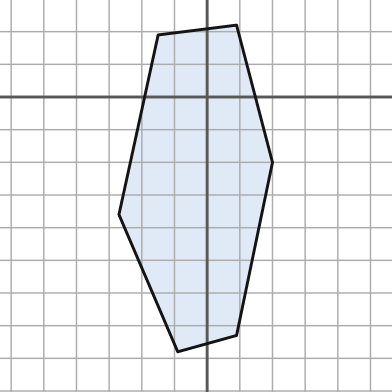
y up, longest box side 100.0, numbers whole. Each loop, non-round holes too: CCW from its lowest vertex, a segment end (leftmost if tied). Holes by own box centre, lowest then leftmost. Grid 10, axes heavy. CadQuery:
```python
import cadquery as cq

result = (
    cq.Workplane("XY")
    .moveTo(-9.0, -78.0)
    .lineTo(9.0, -73.0)
    .lineTo(20.0, -20.0)
    .lineTo(9.0, 22.0)
    .lineTo(-15.0, 19.0)
    .lineTo(-27.0, -36.0)
    .close()
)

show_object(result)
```